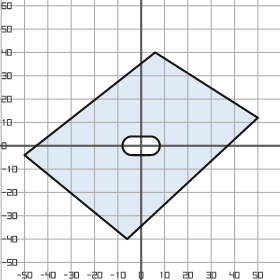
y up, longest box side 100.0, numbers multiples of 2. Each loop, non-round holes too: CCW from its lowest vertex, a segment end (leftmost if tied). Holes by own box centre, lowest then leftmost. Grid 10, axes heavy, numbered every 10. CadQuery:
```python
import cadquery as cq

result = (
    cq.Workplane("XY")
    .moveTo(-6.0, -40.0)
    .lineTo(50.0, 12.0)
    .lineTo(6.0, 40.0)
    .lineTo(-50.0, -4.0)
    .close()
    .moveTo(-4.0, -4.0)
    .lineTo(4.0, -4.0)
    .threePointArc((8.0, 0.0), (4.0, 4.0))
    .lineTo(-4.0, 4.0)
    .threePointArc((-8.0, 0.0), (-4.0, -4.0))
    .close()
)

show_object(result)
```